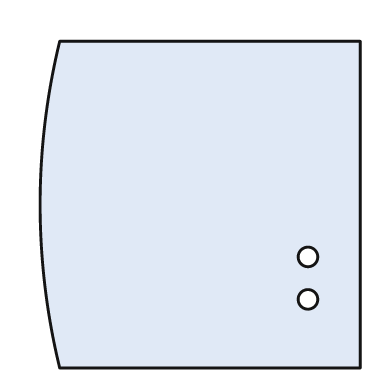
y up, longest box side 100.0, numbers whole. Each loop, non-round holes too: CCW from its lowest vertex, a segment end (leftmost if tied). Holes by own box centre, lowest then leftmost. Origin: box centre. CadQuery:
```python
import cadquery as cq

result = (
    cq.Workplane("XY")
    .moveTo(-43.0, -50.0)
    .lineTo(49.0, -50.0)
    .lineTo(49.0, 50.0)
    .lineTo(-43.0, 50.0)
    .threePointArc((-49.0, 0.0), (-43.0, -50.0))
    .close()
    .moveTo(33.0, -29.0)
    .circle(3.0)
    .moveTo(33.0, -16.0)
    .circle(3.0)
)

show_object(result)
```